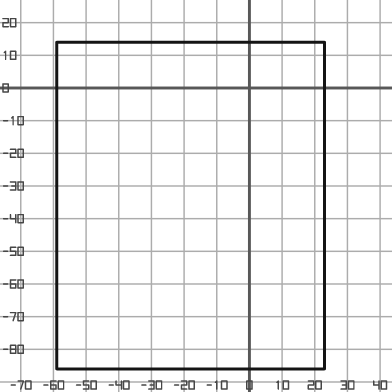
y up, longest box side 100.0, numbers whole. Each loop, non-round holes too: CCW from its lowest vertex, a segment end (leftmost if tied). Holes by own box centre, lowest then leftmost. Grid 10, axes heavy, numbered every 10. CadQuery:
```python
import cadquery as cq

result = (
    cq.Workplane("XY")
    .moveTo(-59.0, -86.0)
    .lineTo(23.0, -86.0)
    .lineTo(23.0, 14.0)
    .lineTo(-59.0, 14.0)
    .close()
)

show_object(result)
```